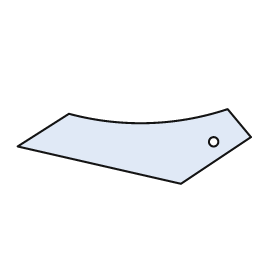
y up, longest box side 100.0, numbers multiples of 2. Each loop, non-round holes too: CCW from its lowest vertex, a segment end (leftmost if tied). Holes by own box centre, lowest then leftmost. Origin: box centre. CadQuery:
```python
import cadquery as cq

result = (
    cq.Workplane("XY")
    .moveTo(20.0, -16.0)
    .lineTo(50.0, 4.0)
    .lineTo(40.0, 16.0)
    .threePointArc((6.0, 10.0), (-28.0, 14.0))
    .lineTo(-50.0, 0.0)
    .close()
    .moveTo(34.0, 2.0)
    .circle(2.0)
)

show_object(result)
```